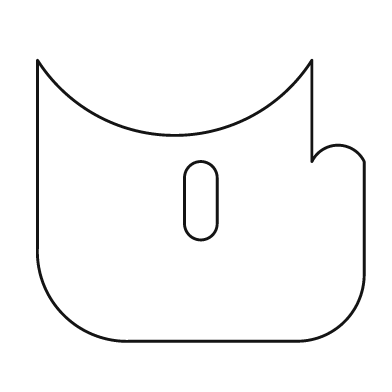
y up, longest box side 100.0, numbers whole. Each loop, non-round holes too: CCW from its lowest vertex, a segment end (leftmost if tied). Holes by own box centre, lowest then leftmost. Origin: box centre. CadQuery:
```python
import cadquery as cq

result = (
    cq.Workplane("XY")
    .moveTo(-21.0, -43.0)
    .lineTo(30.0, -43.0)
    .threePointArc((44.0, -37.0), (50.0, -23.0))
    .lineTo(50.0, 12.0)
    .threePointArc((42.0, 17.0), (34.0, 12.0))
    .lineTo(34.0, 43.0)
    .threePointArc((-8.0, 20.0), (-50.0, 43.0))
    .lineTo(-50.0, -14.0)
    .threePointArc((-42.0, -35.0), (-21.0, -43.0))
    .close()
    .moveTo(-5.0, -7.0)
    .threePointArc((0.0, -12.0), (5.0, -7.0))
    .lineTo(5.0, 7.0)
    .threePointArc((0.0, 12.0), (-5.0, 7.0))
    .close()
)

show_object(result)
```